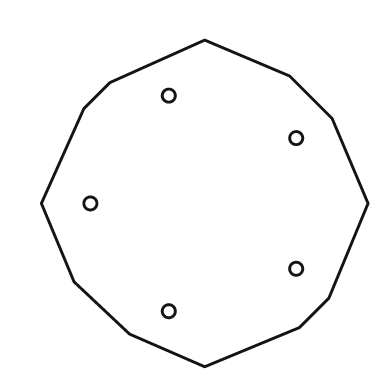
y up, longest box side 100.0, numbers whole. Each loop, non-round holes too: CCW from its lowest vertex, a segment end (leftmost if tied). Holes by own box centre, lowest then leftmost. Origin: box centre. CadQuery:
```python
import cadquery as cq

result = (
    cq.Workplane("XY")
    .moveTo(0.0, -50.0)
    .lineTo(29.0, -38.0)
    .lineTo(38.0, -29.0)
    .lineTo(50.0, 0.0)
    .lineTo(39.0, 26.0)
    .lineTo(26.0, 39.0)
    .lineTo(0.0, 50.0)
    .lineTo(-29.0, 37.0)
    .lineTo(-37.0, 29.0)
    .lineTo(-50.0, 0.0)
    .lineTo(-40.0, -24.0)
    .lineTo(-23.0, -40.0)
    .close()
    .moveTo(-11.0, -33.0)
    .circle(2.0)
    .moveTo(28.0, -20.0)
    .circle(2.0)
    .moveTo(-35.0, 0.0)
    .circle(2.0)
    .moveTo(28.0, 20.0)
    .circle(2.0)
    .moveTo(-11.0, 33.0)
    .circle(2.0)
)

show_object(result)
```